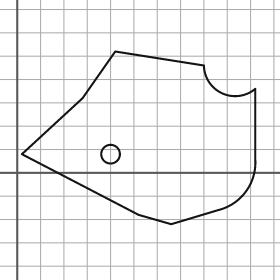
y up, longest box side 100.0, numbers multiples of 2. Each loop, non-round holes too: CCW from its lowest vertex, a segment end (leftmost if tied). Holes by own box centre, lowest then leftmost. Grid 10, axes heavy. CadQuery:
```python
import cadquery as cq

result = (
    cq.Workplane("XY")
    .moveTo(66.0, -22.0)
    .lineTo(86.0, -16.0)
    .threePointArc((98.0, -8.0), (102.0, 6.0))
    .lineTo(102.0, 36.0)
    .threePointArc((88.0, 34.0), (80.0, 46.0))
    .lineTo(42.0, 52.0)
    .lineTo(28.0, 32.0)
    .lineTo(2.0, 8.0)
    .lineTo(52.0, -18.0)
    .close()
    .moveTo(40.0, 8.0)
    .circle(4.0)
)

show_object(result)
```